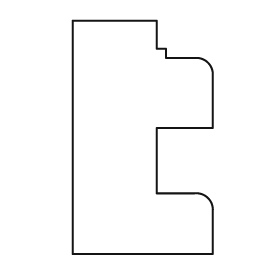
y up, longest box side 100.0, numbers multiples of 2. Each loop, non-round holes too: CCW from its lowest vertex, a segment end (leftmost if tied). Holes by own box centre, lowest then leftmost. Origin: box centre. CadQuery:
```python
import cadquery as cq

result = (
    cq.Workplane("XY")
    .moveTo(-30.0, -50.0)
    .lineTo(30.0, -50.0)
    .lineTo(30.0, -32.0)
    .threePointArc((28.0, -26.0), (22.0, -24.0))
    .lineTo(6.0, -24.0)
    .lineTo(6.0, 4.0)
    .lineTo(30.0, 4.0)
    .lineTo(30.0, 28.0)
    .threePointArc((28.0, 32.0), (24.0, 34.0))
    .lineTo(10.0, 34.0)
    .lineTo(10.0, 38.0)
    .lineTo(6.0, 38.0)
    .lineTo(6.0, 50.0)
    .lineTo(-30.0, 50.0)
    .close()
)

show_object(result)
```